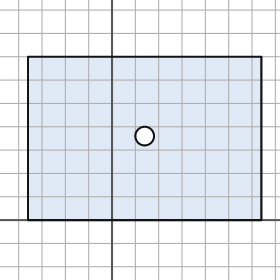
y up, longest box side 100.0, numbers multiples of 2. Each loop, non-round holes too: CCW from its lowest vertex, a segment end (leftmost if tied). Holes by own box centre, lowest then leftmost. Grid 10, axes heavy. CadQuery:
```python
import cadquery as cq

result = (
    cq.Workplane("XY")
    .moveTo(-36.0, 0.0)
    .lineTo(64.0, 0.0)
    .lineTo(64.0, 70.0)
    .lineTo(-36.0, 70.0)
    .close()
    .moveTo(14.0, 36.0)
    .circle(4.0)
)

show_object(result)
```